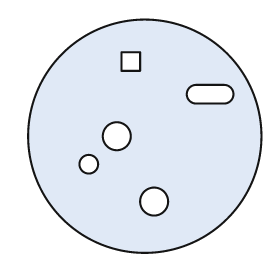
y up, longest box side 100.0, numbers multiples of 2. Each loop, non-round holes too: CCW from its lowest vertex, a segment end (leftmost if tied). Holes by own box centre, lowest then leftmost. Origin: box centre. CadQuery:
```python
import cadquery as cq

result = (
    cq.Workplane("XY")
    .moveTo(0.0, 0.0)
    .circle(50.0)
    .moveTo(4.0, -28.0)
    .circle(6.0)
    .moveTo(-24.0, -12.0)
    .circle(4.0)
    .moveTo(-12.0, 0.0)
    .circle(6.0)
    .moveTo(22.0, 14.0)
    .lineTo(34.0, 14.0)
    .threePointArc((38.0, 18.0), (34.0, 22.0))
    .lineTo(22.0, 22.0)
    .threePointArc((18.0, 18.0), (22.0, 14.0))
    .close()
    .moveTo(-10.0, 28.0)
    .lineTo(-2.0, 28.0)
    .lineTo(-2.0, 36.0)
    .lineTo(-10.0, 36.0)
    .close()
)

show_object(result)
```